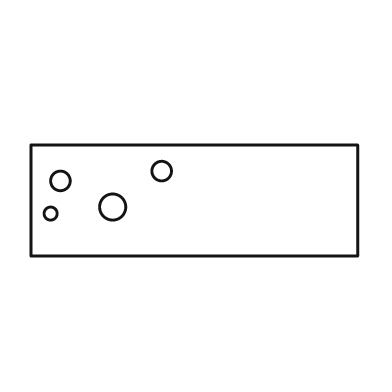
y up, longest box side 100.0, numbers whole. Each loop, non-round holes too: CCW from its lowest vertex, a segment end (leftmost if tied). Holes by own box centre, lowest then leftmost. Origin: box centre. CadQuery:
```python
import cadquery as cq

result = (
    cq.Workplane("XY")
    .moveTo(-50.0, -17.0)
    .lineTo(50.0, -17.0)
    .lineTo(50.0, 17.0)
    .lineTo(-50.0, 17.0)
    .close()
    .moveTo(-44.0, -4.0)
    .circle(2.0)
    .moveTo(-25.0, -2.0)
    .circle(4.0)
    .moveTo(-41.0, 6.0)
    .circle(3.0)
    .moveTo(-10.0, 9.0)
    .circle(3.0)
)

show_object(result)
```